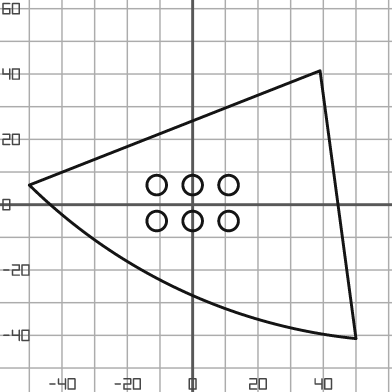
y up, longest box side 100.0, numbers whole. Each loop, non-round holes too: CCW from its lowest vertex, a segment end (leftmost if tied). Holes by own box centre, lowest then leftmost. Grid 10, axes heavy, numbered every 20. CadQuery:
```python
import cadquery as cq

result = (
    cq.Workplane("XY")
    .moveTo(50.0, -41.0)
    .lineTo(39.0, 41.0)
    .lineTo(-50.0, 6.0)
    .threePointArc((-4.0, -26.0), (50.0, -41.0))
    .close()
    .moveTo(-11.0, -5.0)
    .circle(3.0)
    .moveTo(0.0, -5.0)
    .circle(3.0)
    .moveTo(11.0, -5.0)
    .circle(3.0)
    .moveTo(-11.0, 6.0)
    .circle(3.0)
    .moveTo(0.0, 6.0)
    .circle(3.0)
    .moveTo(11.0, 6.0)
    .circle(3.0)
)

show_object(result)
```